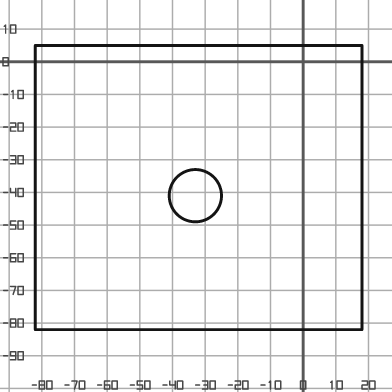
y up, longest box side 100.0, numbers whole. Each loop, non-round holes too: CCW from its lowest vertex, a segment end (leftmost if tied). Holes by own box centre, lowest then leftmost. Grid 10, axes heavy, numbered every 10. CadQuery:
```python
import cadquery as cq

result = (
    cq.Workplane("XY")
    .moveTo(-82.0, -82.0)
    .lineTo(18.0, -82.0)
    .lineTo(18.0, 5.0)
    .lineTo(-82.0, 5.0)
    .close()
    .moveTo(-33.0, -41.0)
    .circle(8.0)
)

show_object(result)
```